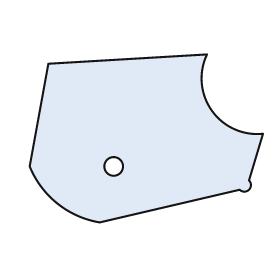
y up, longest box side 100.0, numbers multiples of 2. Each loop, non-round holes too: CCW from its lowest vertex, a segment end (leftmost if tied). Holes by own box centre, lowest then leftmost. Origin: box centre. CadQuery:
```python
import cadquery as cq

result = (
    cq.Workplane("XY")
    .moveTo(-20.0, -36.0)
    .lineTo(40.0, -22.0)
    .threePointArc((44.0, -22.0), (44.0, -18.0))
    .lineTo(50.0, 2.0)
    .threePointArc((28.0, 12.0), (26.0, 36.0))
    .lineTo(-42.0, 32.0)
    .lineTo(-50.0, -12.0)
    .threePointArc((-38.0, -28.0), (-20.0, -36.0))
    .close()
    .moveTo(-14.0, -12.0)
    .circle(4.0)
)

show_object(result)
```